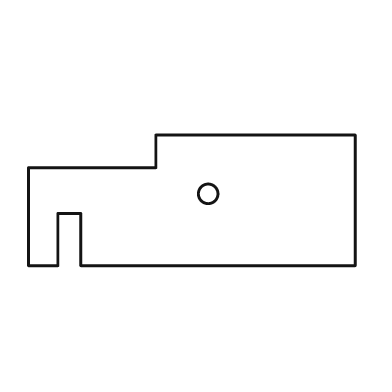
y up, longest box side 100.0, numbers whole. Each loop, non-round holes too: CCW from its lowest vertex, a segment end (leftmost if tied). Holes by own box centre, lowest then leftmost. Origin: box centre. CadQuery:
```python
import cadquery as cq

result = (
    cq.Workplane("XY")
    .moveTo(-50.0, -20.0)
    .lineTo(-41.0, -20.0)
    .lineTo(-41.0, -4.0)
    .lineTo(-34.0, -4.0)
    .lineTo(-34.0, -20.0)
    .lineTo(50.0, -20.0)
    .lineTo(50.0, 20.0)
    .lineTo(-11.0, 20.0)
    .lineTo(-11.0, 10.0)
    .lineTo(-50.0, 10.0)
    .close()
    .moveTo(5.0, 2.0)
    .circle(3.0)
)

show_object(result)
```